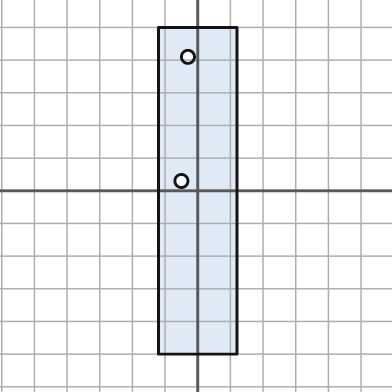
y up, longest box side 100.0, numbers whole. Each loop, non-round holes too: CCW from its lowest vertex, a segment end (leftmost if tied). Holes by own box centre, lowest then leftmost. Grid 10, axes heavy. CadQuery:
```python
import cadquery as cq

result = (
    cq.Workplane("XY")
    .moveTo(-12.0, -50.0)
    .lineTo(12.0, -50.0)
    .lineTo(12.0, 50.0)
    .lineTo(-12.0, 50.0)
    .close()
    .moveTo(-5.0, 3.0)
    .circle(2.0)
    .moveTo(-3.0, 41.0)
    .circle(2.0)
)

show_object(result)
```